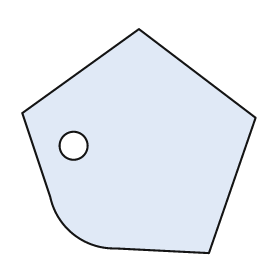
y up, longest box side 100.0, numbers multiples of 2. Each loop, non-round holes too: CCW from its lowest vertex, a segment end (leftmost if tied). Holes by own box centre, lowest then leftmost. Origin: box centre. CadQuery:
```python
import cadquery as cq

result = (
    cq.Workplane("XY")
    .moveTo(30.0, -48.0)
    .lineTo(50.0, 10.0)
    .lineTo(0.0, 48.0)
    .lineTo(-50.0, 12.0)
    .lineTo(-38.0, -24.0)
    .threePointArc((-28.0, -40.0), (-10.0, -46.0))
    .close()
    .moveTo(-28.0, -2.0)
    .circle(6.0)
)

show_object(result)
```